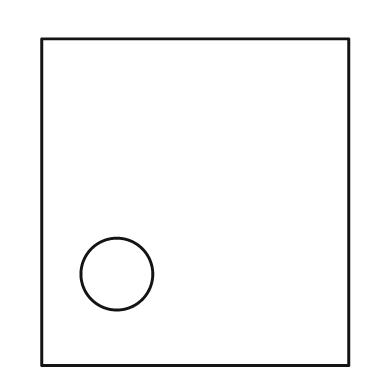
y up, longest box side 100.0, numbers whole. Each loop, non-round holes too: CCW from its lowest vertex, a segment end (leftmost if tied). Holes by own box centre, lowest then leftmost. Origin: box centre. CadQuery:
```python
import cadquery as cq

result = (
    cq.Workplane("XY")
    .moveTo(-47.0, -50.0)
    .lineTo(47.0, -50.0)
    .lineTo(47.0, 50.0)
    .lineTo(-47.0, 50.0)
    .close()
    .moveTo(-24.0, -22.0)
    .circle(11.0)
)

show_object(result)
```